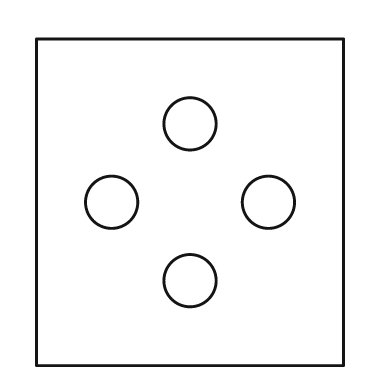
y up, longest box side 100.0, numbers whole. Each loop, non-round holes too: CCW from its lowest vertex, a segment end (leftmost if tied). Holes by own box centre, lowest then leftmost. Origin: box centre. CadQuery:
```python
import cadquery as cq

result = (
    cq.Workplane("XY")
    .moveTo(-47.0, -50.0)
    .lineTo(47.0, -50.0)
    .lineTo(47.0, 50.0)
    .lineTo(-47.0, 50.0)
    .close()
    .moveTo(0.0, -24.0)
    .circle(8.0)
    .moveTo(-24.0, 0.0)
    .circle(8.0)
    .moveTo(24.0, 0.0)
    .circle(8.0)
    .moveTo(0.0, 24.0)
    .circle(8.0)
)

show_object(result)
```